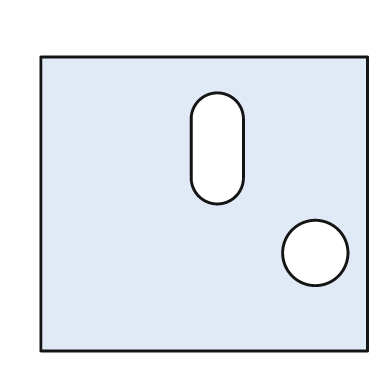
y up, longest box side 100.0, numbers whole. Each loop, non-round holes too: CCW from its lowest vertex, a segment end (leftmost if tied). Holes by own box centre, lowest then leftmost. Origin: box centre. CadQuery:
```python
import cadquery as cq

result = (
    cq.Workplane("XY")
    .moveTo(-50.0, -45.0)
    .lineTo(50.0, -45.0)
    .lineTo(50.0, 45.0)
    .lineTo(-50.0, 45.0)
    .close()
    .moveTo(34.0, -15.0)
    .circle(10.0)
    .moveTo(-4.0, 8.0)
    .threePointArc((4.0, 0.0), (12.0, 8.0))
    .lineTo(12.0, 26.0)
    .threePointArc((4.0, 34.0), (-4.0, 26.0))
    .close()
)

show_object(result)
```